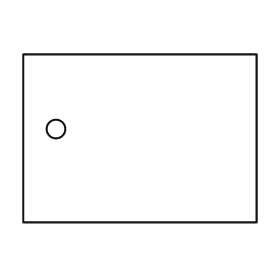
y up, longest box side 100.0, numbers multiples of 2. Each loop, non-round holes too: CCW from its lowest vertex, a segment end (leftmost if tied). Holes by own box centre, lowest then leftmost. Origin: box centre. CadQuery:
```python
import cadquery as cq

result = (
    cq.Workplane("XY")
    .moveTo(-50.0, -36.0)
    .lineTo(50.0, -36.0)
    .lineTo(50.0, 36.0)
    .lineTo(-50.0, 36.0)
    .close()
    .moveTo(-36.0, 4.0)
    .circle(4.0)
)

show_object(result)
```